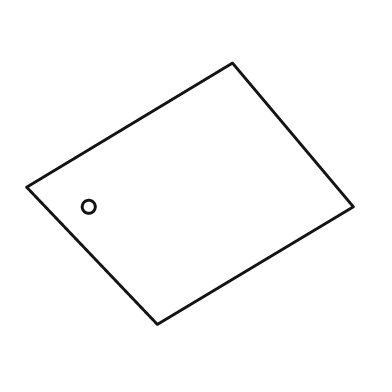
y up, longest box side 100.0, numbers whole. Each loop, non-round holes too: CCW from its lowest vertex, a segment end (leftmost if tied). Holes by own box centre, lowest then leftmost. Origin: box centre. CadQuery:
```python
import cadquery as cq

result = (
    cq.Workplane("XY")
    .moveTo(-10.0, -40.0)
    .lineTo(50.0, -4.0)
    .lineTo(13.0, 40.0)
    .lineTo(-50.0, 2.0)
    .close()
    .moveTo(-31.0, -4.0)
    .circle(2.0)
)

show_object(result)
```